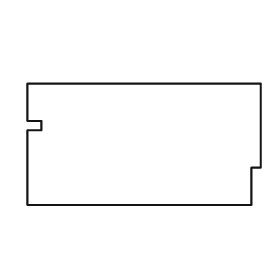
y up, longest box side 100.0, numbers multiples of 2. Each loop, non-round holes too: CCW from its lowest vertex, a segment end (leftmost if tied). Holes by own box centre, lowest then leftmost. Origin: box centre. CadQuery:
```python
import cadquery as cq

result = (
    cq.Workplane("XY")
    .moveTo(-50.0, -26.0)
    .lineTo(46.0, -26.0)
    .lineTo(46.0, -10.0)
    .lineTo(50.0, -10.0)
    .lineTo(50.0, 26.0)
    .lineTo(-50.0, 26.0)
    .lineTo(-50.0, 10.0)
    .lineTo(-44.0, 10.0)
    .lineTo(-44.0, 6.0)
    .lineTo(-50.0, 6.0)
    .close()
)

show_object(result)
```